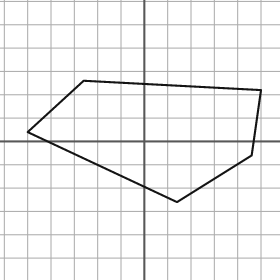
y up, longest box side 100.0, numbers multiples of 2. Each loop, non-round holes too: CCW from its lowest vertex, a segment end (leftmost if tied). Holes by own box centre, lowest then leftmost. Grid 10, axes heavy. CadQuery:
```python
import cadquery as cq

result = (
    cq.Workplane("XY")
    .moveTo(14.0, -26.0)
    .lineTo(46.0, -6.0)
    .lineTo(50.0, 22.0)
    .lineTo(-26.0, 26.0)
    .lineTo(-50.0, 4.0)
    .close()
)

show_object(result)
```